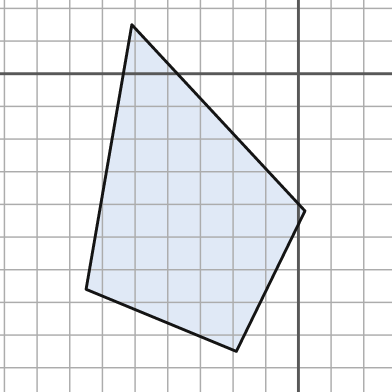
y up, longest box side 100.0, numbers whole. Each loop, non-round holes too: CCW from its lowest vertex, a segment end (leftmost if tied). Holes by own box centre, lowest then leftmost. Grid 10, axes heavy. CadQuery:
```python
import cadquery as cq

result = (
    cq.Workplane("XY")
    .moveTo(-19.0, -85.0)
    .lineTo(2.0, -42.0)
    .lineTo(-51.0, 15.0)
    .lineTo(-65.0, -66.0)
    .close()
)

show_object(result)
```